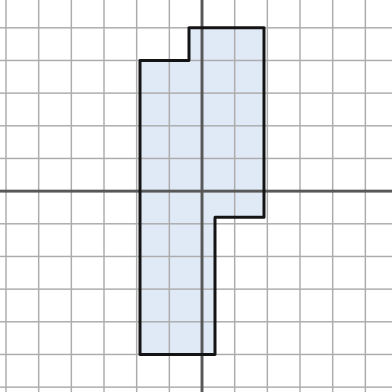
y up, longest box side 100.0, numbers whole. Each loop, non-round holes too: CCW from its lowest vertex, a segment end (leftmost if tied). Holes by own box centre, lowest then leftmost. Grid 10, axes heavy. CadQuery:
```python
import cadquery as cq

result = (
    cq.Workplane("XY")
    .moveTo(-19.0, -50.0)
    .lineTo(4.0, -50.0)
    .lineTo(4.0, -8.0)
    .lineTo(19.0, -8.0)
    .lineTo(19.0, 50.0)
    .lineTo(-4.0, 50.0)
    .lineTo(-4.0, 40.0)
    .lineTo(-19.0, 40.0)
    .close()
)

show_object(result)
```